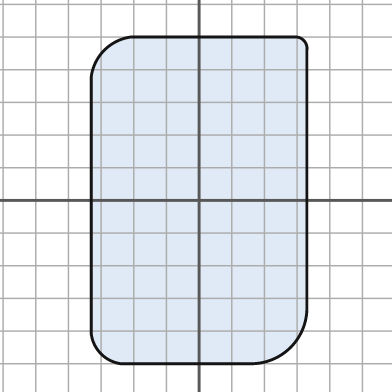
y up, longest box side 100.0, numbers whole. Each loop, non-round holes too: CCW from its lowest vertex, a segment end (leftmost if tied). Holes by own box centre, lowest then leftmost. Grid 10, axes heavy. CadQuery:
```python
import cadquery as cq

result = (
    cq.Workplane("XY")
    .moveTo(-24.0, -50.0)
    .lineTo(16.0, -50.0)
    .threePointArc((28.0, -45.0), (33.0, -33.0))
    .lineTo(33.0, 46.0)
    .threePointArc((32.0, 49.0), (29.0, 50.0))
    .lineTo(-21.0, 50.0)
    .threePointArc((-29.0, 46.0), (-33.0, 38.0))
    .lineTo(-33.0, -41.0)
    .threePointArc((-30.0, -47.0), (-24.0, -50.0))
    .close()
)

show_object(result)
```